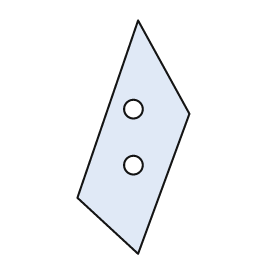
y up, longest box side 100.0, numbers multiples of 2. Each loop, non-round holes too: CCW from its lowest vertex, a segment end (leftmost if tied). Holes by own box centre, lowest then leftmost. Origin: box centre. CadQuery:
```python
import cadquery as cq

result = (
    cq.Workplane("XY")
    .moveTo(2.0, -50.0)
    .lineTo(24.0, 10.0)
    .lineTo(2.0, 50.0)
    .lineTo(-24.0, -26.0)
    .close()
    .moveTo(0.0, -12.0)
    .circle(4.0)
    .moveTo(0.0, 12.0)
    .circle(4.0)
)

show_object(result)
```